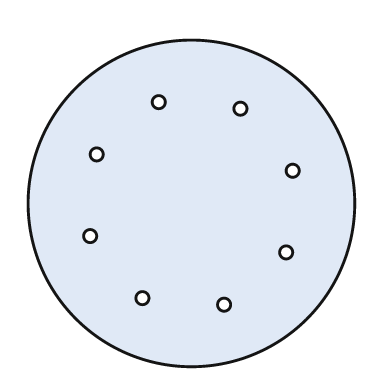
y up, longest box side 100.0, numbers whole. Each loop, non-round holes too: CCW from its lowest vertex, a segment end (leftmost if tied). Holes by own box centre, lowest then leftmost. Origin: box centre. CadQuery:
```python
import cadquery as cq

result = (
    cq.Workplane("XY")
    .moveTo(0.0, 0.0)
    .circle(50.0)
    .moveTo(10.0, -31.0)
    .circle(2.0)
    .moveTo(-15.0, -29.0)
    .circle(2.0)
    .moveTo(29.0, -15.0)
    .circle(2.0)
    .moveTo(-31.0, -10.0)
    .circle(2.0)
    .moveTo(31.0, 10.0)
    .circle(2.0)
    .moveTo(-29.0, 15.0)
    .circle(2.0)
    .moveTo(15.0, 29.0)
    .circle(2.0)
    .moveTo(-10.0, 31.0)
    .circle(2.0)
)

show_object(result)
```